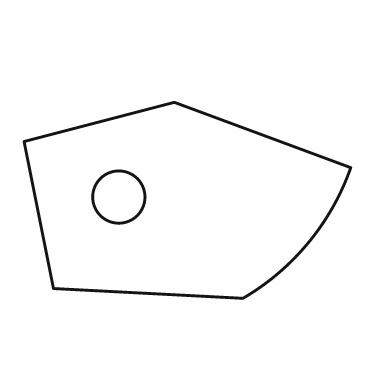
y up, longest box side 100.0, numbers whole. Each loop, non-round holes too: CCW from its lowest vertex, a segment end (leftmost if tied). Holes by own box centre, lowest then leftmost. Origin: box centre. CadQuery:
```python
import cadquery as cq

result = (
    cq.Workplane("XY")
    .moveTo(17.0, -30.0)
    .threePointArc((37.0, -13.0), (50.0, 10.0))
    .lineTo(-4.0, 30.0)
    .lineTo(-50.0, 18.0)
    .lineTo(-41.0, -27.0)
    .close()
    .moveTo(-21.0, 1.0)
    .circle(8.0)
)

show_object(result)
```